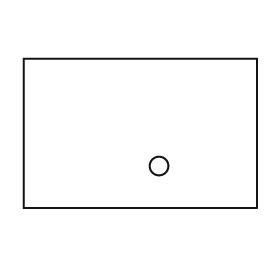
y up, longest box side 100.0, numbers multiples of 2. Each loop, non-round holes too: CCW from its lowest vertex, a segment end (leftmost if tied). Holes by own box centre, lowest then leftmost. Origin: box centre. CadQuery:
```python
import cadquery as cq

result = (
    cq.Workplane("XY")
    .moveTo(-50.0, -32.0)
    .lineTo(50.0, -32.0)
    .lineTo(50.0, 32.0)
    .lineTo(-50.0, 32.0)
    .close()
    .moveTo(8.0, -14.0)
    .circle(4.0)
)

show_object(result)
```